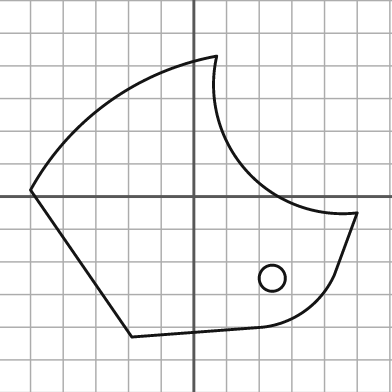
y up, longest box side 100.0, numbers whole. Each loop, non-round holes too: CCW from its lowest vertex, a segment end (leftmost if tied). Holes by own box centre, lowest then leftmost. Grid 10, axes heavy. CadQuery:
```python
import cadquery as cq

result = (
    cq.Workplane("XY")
    .moveTo(-19.0, -43.0)
    .lineTo(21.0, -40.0)
    .threePointArc((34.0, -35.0), (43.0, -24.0))
    .lineTo(50.0, -5.0)
    .threePointArc((16.0, 8.0), (7.0, 43.0))
    .threePointArc((-26.0, 29.0), (-50.0, 2.0))
    .close()
    .moveTo(24.0, -25.0)
    .circle(4.0)
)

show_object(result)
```